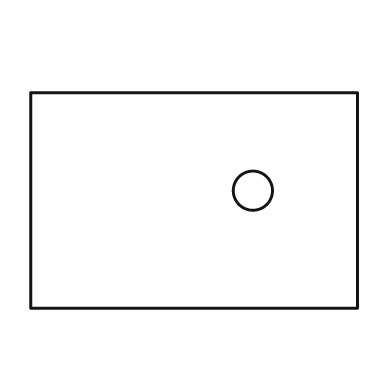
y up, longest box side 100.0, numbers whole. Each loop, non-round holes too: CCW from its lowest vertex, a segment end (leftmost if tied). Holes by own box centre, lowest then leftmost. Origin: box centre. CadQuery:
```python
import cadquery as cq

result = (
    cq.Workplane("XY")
    .moveTo(-50.0, -33.0)
    .lineTo(50.0, -33.0)
    .lineTo(50.0, 33.0)
    .lineTo(-50.0, 33.0)
    .close()
    .moveTo(18.0, 3.0)
    .circle(6.0)
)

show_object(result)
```